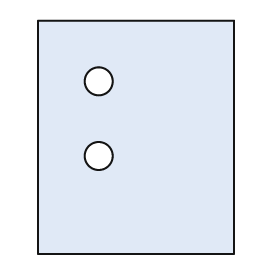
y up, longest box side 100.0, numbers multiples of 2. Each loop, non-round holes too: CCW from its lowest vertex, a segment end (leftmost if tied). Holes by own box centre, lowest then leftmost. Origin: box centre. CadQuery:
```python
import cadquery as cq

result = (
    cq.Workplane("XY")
    .moveTo(-42.0, -50.0)
    .lineTo(42.0, -50.0)
    .lineTo(42.0, 50.0)
    .lineTo(-42.0, 50.0)
    .close()
    .moveTo(-16.0, -8.0)
    .circle(6.0)
    .moveTo(-16.0, 24.0)
    .circle(6.0)
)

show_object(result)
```